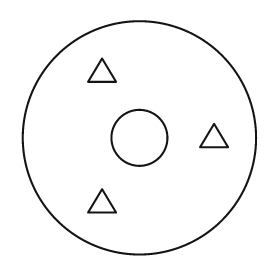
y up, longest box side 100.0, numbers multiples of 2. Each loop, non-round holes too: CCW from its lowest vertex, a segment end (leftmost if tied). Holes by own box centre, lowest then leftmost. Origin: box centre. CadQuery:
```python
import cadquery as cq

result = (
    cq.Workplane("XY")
    .moveTo(0.0, 0.0)
    .circle(50.0)
    .moveTo(-22.0, -32.0)
    .lineTo(-10.0, -32.0)
    .lineTo(-16.0, -22.0)
    .close()
    .moveTo(0.0, 0.0)
    .circle(12.0)
    .moveTo(26.0, -4.0)
    .lineTo(38.0, -4.0)
    .lineTo(32.0, 6.0)
    .close()
    .moveTo(-22.0, 24.0)
    .lineTo(-10.0, 24.0)
    .lineTo(-16.0, 34.0)
    .close()
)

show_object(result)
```